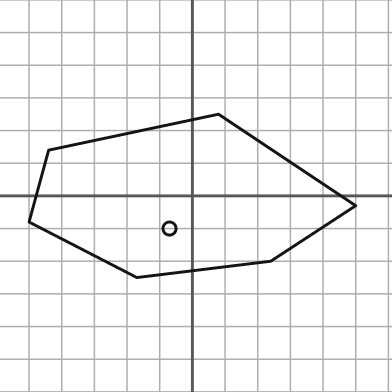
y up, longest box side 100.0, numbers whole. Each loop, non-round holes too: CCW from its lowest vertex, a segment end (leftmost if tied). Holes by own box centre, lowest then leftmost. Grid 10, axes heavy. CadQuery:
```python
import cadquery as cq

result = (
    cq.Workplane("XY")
    .moveTo(-17.0, -25.0)
    .lineTo(24.0, -20.0)
    .lineTo(50.0, -3.0)
    .lineTo(8.0, 25.0)
    .lineTo(-44.0, 14.0)
    .lineTo(-50.0, -8.0)
    .close()
    .moveTo(-7.0, -10.0)
    .circle(2.0)
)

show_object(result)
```